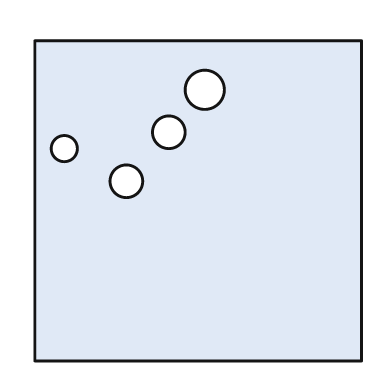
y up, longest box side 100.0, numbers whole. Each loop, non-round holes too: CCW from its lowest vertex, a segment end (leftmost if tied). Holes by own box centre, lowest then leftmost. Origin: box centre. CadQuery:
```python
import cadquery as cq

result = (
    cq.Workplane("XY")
    .moveTo(-50.0, -49.0)
    .lineTo(50.0, -49.0)
    .lineTo(50.0, 49.0)
    .lineTo(-50.0, 49.0)
    .close()
    .moveTo(-22.0, 6.0)
    .circle(5.0)
    .moveTo(-41.0, 16.0)
    .circle(4.0)
    .moveTo(-9.0, 21.0)
    .circle(5.0)
    .moveTo(2.0, 34.0)
    .circle(6.0)
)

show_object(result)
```